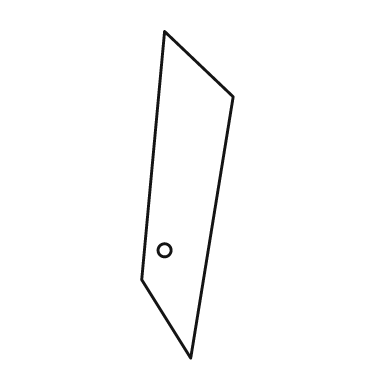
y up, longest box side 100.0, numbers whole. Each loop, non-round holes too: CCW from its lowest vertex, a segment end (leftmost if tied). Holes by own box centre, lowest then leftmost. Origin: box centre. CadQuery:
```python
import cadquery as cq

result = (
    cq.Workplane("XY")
    .moveTo(1.0, -50.0)
    .lineTo(14.0, 30.0)
    .lineTo(-7.0, 50.0)
    .lineTo(-14.0, -26.0)
    .close()
    .moveTo(-7.0, -17.0)
    .circle(2.0)
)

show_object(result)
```